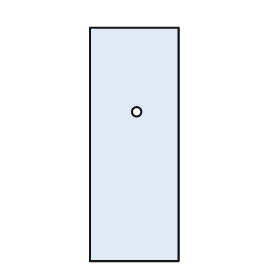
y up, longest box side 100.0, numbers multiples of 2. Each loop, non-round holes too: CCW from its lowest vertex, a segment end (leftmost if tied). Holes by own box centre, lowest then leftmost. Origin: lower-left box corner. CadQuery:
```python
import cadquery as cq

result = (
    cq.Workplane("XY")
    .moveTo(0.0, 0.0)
    .lineTo(38.0, 0.0)
    .lineTo(38.0, 100.0)
    .lineTo(0.0, 100.0)
    .close()
    .moveTo(20.0, 64.0)
    .circle(2.0)
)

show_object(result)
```